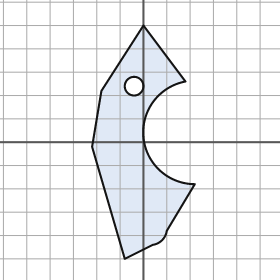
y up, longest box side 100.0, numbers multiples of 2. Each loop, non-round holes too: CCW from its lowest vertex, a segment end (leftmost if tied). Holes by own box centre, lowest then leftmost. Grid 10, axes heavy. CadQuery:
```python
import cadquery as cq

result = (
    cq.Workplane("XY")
    .moveTo(-8.0, -50.0)
    .lineTo(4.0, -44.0)
    .threePointArc((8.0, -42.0), (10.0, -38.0))
    .lineTo(22.0, -18.0)
    .threePointArc((0.0, 2.0), (18.0, 26.0))
    .lineTo(0.0, 50.0)
    .lineTo(-18.0, 22.0)
    .lineTo(-22.0, -2.0)
    .close()
    .moveTo(-4.0, 24.0)
    .circle(4.0)
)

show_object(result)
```